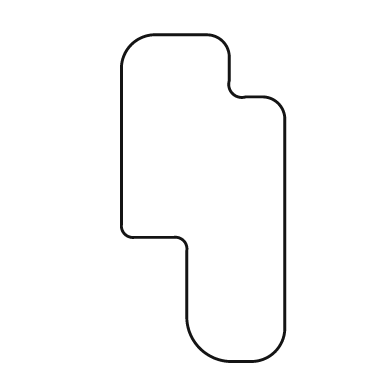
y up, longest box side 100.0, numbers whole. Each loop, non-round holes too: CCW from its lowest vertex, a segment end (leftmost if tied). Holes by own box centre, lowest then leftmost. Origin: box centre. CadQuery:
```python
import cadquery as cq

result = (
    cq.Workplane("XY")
    .moveTo(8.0, -50.0)
    .lineTo(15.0, -50.0)
    .threePointArc((22.0, -47.0), (25.0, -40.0))
    .lineTo(25.0, 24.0)
    .threePointArc((23.0, 29.0), (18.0, 31.0))
    .lineTo(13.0, 31.0)
    .threePointArc((9.0, 32.0), (8.0, 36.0))
    .lineTo(8.0, 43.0)
    .threePointArc((6.0, 48.0), (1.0, 50.0))
    .lineTo(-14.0, 50.0)
    .threePointArc((-22.0, 47.0), (-25.0, 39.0))
    .lineTo(-25.0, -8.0)
    .threePointArc((-24.0, -11.0), (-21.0, -12.0))
    .lineTo(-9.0, -12.0)
    .threePointArc((-6.0, -13.0), (-5.0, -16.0))
    .lineTo(-5.0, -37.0)
    .threePointArc((-1.0, -46.0), (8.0, -50.0))
    .close()
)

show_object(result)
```